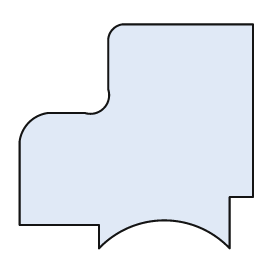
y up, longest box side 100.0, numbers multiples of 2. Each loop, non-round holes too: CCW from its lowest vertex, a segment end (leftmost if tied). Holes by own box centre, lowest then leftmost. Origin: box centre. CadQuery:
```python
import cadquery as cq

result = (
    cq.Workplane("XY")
    .moveTo(-16.0, -48.0)
    .threePointArc((12.0, -36.0), (40.0, -48.0))
    .lineTo(40.0, -26.0)
    .lineTo(50.0, -26.0)
    .lineTo(50.0, 48.0)
    .lineTo(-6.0, 48.0)
    .threePointArc((-10.0, 46.0), (-12.0, 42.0))
    .lineTo(-12.0, 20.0)
    .threePointArc((-14.0, 12.0), (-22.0, 10.0))
    .lineTo(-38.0, 10.0)
    .threePointArc((-46.0, 6.0), (-50.0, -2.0))
    .lineTo(-50.0, -38.0)
    .lineTo(-16.0, -38.0)
    .close()
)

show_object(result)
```